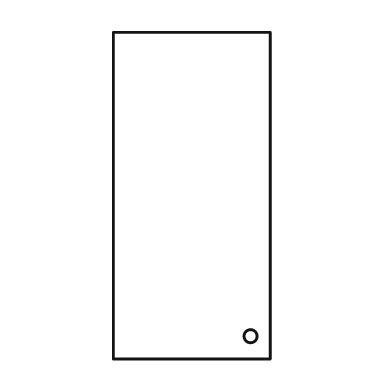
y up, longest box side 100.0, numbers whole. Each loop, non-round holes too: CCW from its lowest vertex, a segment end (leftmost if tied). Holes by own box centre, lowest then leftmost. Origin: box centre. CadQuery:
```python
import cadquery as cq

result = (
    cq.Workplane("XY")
    .moveTo(-24.0, -50.0)
    .lineTo(24.0, -50.0)
    .lineTo(24.0, 50.0)
    .lineTo(-24.0, 50.0)
    .close()
    .moveTo(18.0, -43.0)
    .circle(2.0)
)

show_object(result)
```